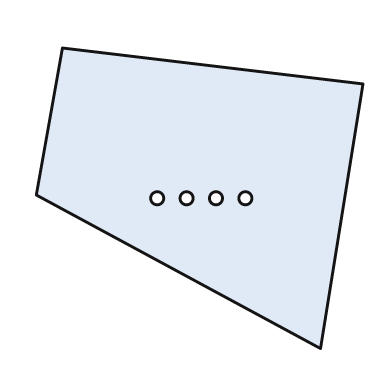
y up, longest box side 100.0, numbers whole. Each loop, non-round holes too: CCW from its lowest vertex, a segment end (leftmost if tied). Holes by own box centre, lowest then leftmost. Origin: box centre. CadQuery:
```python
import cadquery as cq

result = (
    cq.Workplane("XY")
    .moveTo(37.0, -46.0)
    .lineTo(50.0, 35.0)
    .lineTo(-42.0, 46.0)
    .lineTo(-50.0, 1.0)
    .close()
    .moveTo(-13.0, 0.0)
    .circle(2.0)
    .moveTo(-4.0, 0.0)
    .circle(2.0)
    .moveTo(5.0, 0.0)
    .circle(2.0)
    .moveTo(14.0, 0.0)
    .circle(2.0)
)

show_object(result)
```